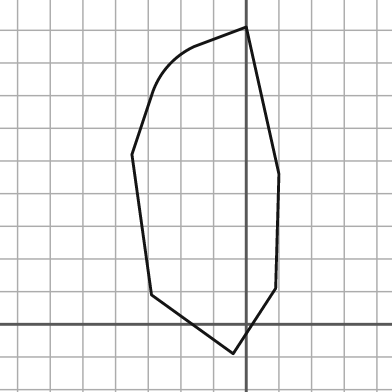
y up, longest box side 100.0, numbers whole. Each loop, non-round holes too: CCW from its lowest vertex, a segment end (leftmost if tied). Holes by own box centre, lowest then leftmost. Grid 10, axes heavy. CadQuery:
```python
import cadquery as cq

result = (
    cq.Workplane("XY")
    .moveTo(-4.0, -9.0)
    .lineTo(9.0, 11.0)
    .lineTo(10.0, 46.0)
    .lineTo(0.0, 91.0)
    .lineTo(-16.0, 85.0)
    .threePointArc((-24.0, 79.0), (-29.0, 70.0))
    .lineTo(-35.0, 52.0)
    .lineTo(-29.0, 9.0)
    .close()
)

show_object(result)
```